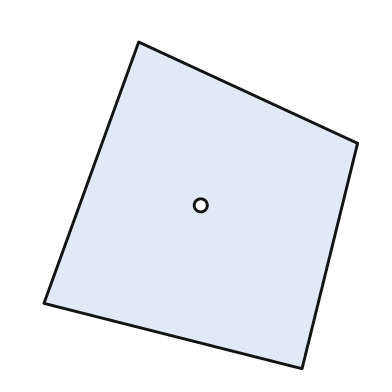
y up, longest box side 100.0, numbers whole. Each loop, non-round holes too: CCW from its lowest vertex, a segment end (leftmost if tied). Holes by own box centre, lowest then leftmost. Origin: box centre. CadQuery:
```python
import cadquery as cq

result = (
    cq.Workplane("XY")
    .moveTo(31.0, -50.0)
    .lineTo(48.0, 19.0)
    .lineTo(-19.0, 50.0)
    .lineTo(-48.0, -30.0)
    .close()
    .moveTo(0.0, 0.0)
    .circle(2.0)
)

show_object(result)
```